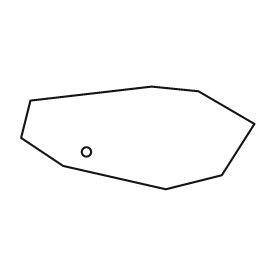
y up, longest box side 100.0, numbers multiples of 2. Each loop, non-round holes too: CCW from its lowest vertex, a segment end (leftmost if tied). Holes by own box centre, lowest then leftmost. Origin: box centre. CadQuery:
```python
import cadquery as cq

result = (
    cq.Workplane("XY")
    .moveTo(12.0, -22.0)
    .lineTo(36.0, -16.0)
    .lineTo(50.0, 6.0)
    .lineTo(26.0, 20.0)
    .lineTo(6.0, 22.0)
    .lineTo(-46.0, 16.0)
    .lineTo(-50.0, 0.0)
    .lineTo(-32.0, -12.0)
    .close()
    .moveTo(-22.0, -6.0)
    .circle(2.0)
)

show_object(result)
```